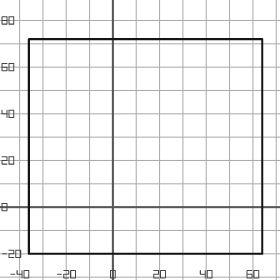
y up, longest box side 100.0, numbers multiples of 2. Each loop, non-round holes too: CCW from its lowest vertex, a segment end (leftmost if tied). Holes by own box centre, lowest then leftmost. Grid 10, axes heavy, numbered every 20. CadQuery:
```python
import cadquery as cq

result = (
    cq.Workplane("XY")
    .moveTo(-36.0, -20.0)
    .lineTo(64.0, -20.0)
    .lineTo(64.0, 72.0)
    .lineTo(-36.0, 72.0)
    .close()
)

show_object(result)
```